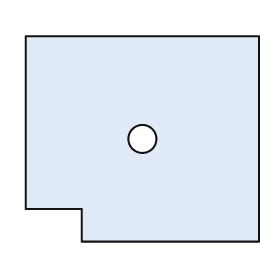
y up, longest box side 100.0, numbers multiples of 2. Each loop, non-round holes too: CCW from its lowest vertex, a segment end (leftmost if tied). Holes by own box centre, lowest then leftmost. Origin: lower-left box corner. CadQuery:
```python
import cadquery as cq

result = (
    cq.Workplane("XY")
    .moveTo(24.0, 0.0)
    .lineTo(100.0, 0.0)
    .lineTo(100.0, 88.0)
    .lineTo(0.0, 88.0)
    .lineTo(0.0, 14.0)
    .lineTo(24.0, 14.0)
    .close()
    .moveTo(50.0, 44.0)
    .circle(6.0)
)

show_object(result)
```